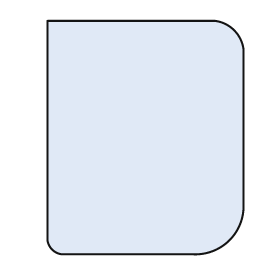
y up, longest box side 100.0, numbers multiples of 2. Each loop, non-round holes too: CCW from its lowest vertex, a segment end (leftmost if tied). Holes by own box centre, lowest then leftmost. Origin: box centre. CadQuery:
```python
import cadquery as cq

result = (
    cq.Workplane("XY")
    .moveTo(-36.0, -50.0)
    .lineTo(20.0, -50.0)
    .threePointArc((36.0, -44.0), (42.0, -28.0))
    .lineTo(42.0, 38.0)
    .threePointArc((38.0, 46.0), (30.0, 50.0))
    .lineTo(-42.0, 50.0)
    .lineTo(-42.0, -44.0)
    .threePointArc((-40.0, -48.0), (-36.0, -50.0))
    .close()
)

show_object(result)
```